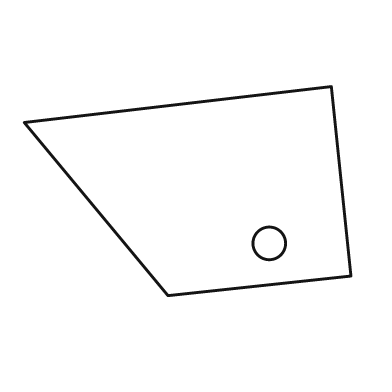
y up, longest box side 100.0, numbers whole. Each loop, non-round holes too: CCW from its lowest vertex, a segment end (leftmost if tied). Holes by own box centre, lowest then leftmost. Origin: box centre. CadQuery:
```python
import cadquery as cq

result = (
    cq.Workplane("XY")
    .moveTo(-6.0, -32.0)
    .lineTo(50.0, -26.0)
    .lineTo(44.0, 32.0)
    .lineTo(-50.0, 21.0)
    .close()
    .moveTo(25.0, -16.0)
    .circle(5.0)
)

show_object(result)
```